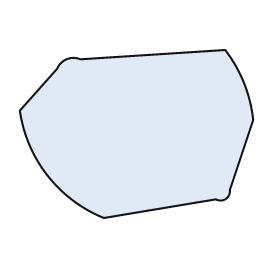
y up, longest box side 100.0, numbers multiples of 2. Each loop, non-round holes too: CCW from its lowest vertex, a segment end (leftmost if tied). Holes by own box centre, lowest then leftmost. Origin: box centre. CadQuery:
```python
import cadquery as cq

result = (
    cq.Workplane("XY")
    .moveTo(-14.0, -36.0)
    .lineTo(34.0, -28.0)
    .threePointArc((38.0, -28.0), (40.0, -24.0))
    .lineTo(50.0, 6.0)
    .threePointArc((46.0, 22.0), (38.0, 36.0))
    .lineTo(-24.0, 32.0)
    .threePointArc((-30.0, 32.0), (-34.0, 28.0))
    .lineTo(-50.0, 10.0)
    .threePointArc((-38.0, -18.0), (-14.0, -36.0))
    .close()
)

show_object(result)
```